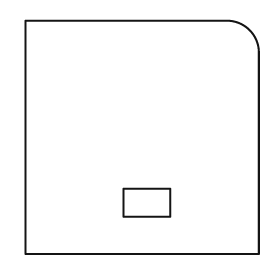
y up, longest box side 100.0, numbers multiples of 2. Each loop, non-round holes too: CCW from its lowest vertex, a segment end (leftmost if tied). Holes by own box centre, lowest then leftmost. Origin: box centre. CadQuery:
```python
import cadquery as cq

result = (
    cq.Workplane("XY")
    .moveTo(-50.0, -50.0)
    .lineTo(50.0, -50.0)
    .lineTo(50.0, 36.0)
    .threePointArc((46.0, 46.0), (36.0, 50.0))
    .lineTo(-50.0, 50.0)
    .close()
    .moveTo(-8.0, -34.0)
    .lineTo(12.0, -34.0)
    .lineTo(12.0, -22.0)
    .lineTo(-8.0, -22.0)
    .close()
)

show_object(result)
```